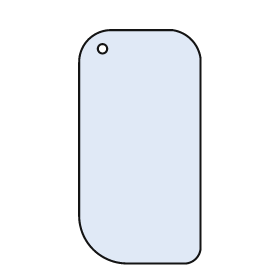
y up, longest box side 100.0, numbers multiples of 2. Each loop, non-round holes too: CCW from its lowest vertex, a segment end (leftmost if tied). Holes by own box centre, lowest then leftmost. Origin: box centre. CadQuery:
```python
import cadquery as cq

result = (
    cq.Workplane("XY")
    .moveTo(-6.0, -50.0)
    .lineTo(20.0, -50.0)
    .threePointArc((24.0, -48.0), (26.0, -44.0))
    .lineTo(26.0, 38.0)
    .threePointArc((22.0, 46.0), (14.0, 50.0))
    .lineTo(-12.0, 50.0)
    .threePointArc((-22.0, 46.0), (-26.0, 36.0))
    .lineTo(-26.0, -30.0)
    .threePointArc((-20.0, -44.0), (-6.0, -50.0))
    .close()
    .moveTo(-16.0, 42.0)
    .circle(2.0)
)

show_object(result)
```